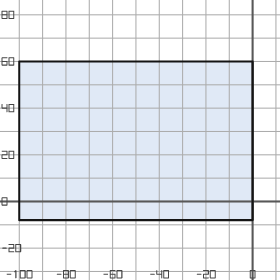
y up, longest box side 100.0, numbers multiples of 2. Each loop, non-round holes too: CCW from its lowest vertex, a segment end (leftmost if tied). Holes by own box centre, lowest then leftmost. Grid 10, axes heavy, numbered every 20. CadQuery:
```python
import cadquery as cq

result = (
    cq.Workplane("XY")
    .moveTo(-100.0, -8.0)
    .lineTo(0.0, -8.0)
    .lineTo(0.0, 60.0)
    .lineTo(-100.0, 60.0)
    .close()
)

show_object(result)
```